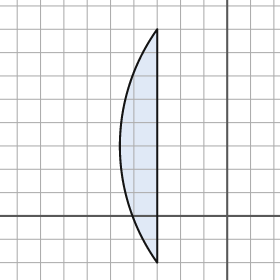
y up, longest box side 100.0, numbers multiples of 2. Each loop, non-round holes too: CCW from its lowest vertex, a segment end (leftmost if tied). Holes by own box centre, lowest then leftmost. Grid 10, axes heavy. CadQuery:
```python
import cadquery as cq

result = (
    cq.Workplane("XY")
    .moveTo(-30.0, -20.0)
    .lineTo(-30.0, 80.0)
    .threePointArc((-46.0, 30.0), (-30.0, -20.0))
    .close()
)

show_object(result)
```